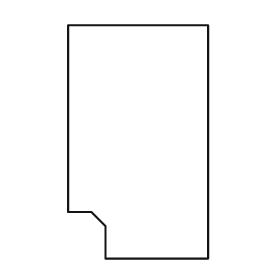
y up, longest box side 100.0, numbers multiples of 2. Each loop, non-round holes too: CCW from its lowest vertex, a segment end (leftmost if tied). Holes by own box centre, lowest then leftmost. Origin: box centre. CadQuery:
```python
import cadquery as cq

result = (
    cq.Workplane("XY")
    .moveTo(-14.0, -50.0)
    .lineTo(30.0, -50.0)
    .lineTo(30.0, 50.0)
    .lineTo(-30.0, 50.0)
    .lineTo(-30.0, -30.0)
    .lineTo(-20.0, -30.0)
    .lineTo(-14.0, -36.0)
    .close()
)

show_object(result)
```